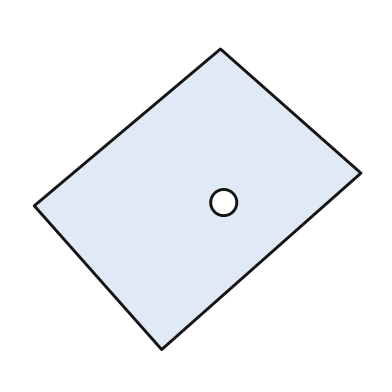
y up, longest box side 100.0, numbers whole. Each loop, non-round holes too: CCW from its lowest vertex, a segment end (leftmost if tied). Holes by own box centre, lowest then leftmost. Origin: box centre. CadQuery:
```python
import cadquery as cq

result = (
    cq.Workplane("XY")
    .moveTo(-11.0, -46.0)
    .lineTo(50.0, 8.0)
    .lineTo(7.0, 46.0)
    .lineTo(-50.0, -2.0)
    .close()
    .moveTo(8.0, -1.0)
    .circle(4.0)
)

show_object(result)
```